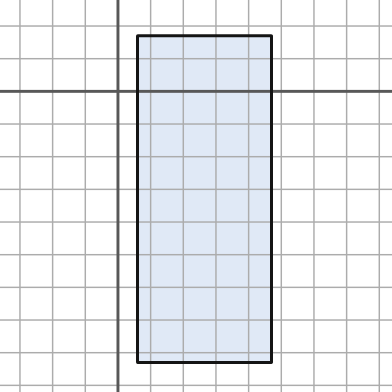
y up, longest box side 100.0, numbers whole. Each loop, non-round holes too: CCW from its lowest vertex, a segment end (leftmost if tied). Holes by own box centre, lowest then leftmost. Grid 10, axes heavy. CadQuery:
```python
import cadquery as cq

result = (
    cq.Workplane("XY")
    .moveTo(6.0, -83.0)
    .lineTo(47.0, -83.0)
    .lineTo(47.0, 17.0)
    .lineTo(6.0, 17.0)
    .close()
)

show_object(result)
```